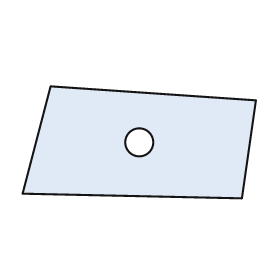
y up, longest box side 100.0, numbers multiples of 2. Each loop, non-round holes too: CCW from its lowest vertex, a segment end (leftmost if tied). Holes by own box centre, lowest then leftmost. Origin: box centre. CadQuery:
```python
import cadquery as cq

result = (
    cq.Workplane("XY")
    .moveTo(44.0, -24.0)
    .lineTo(50.0, 18.0)
    .lineTo(-38.0, 24.0)
    .lineTo(-50.0, -22.0)
    .close()
    .moveTo(0.0, 0.0)
    .circle(6.0)
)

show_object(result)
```